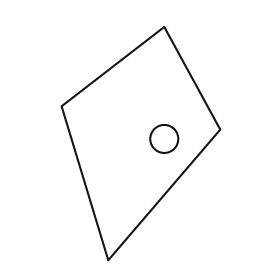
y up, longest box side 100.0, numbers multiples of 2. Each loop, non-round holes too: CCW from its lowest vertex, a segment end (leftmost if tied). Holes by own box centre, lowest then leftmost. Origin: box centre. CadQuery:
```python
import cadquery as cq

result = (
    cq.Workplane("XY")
    .moveTo(-14.0, -50.0)
    .lineTo(34.0, 6.0)
    .lineTo(10.0, 50.0)
    .lineTo(-34.0, 16.0)
    .close()
    .moveTo(10.0, 2.0)
    .circle(6.0)
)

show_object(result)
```